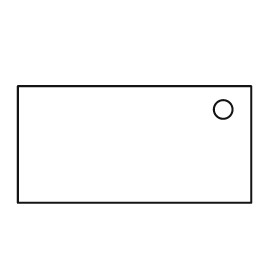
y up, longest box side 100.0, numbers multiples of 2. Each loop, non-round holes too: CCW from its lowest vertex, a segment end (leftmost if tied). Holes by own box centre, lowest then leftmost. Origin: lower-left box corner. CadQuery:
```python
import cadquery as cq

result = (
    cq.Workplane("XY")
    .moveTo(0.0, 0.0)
    .lineTo(100.0, 0.0)
    .lineTo(100.0, 50.0)
    .lineTo(0.0, 50.0)
    .close()
    .moveTo(88.0, 40.0)
    .circle(4.0)
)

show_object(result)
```